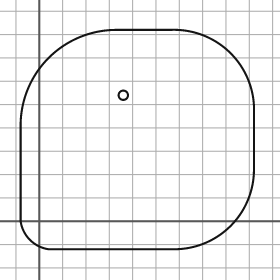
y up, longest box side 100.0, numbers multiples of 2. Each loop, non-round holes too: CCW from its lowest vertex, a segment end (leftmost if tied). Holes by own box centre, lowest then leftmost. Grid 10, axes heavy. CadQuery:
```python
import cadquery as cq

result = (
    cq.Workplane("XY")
    .moveTo(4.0, -12.0)
    .lineTo(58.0, -12.0)
    .threePointArc((82.0, -2.0), (92.0, 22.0))
    .lineTo(92.0, 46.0)
    .threePointArc((82.0, 72.0), (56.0, 82.0))
    .lineTo(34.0, 82.0)
    .threePointArc((4.0, 70.0), (-8.0, 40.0))
    .lineTo(-8.0, 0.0)
    .threePointArc((-4.0, -8.0), (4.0, -12.0))
    .close()
    .moveTo(36.0, 54.0)
    .circle(2.0)
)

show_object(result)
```